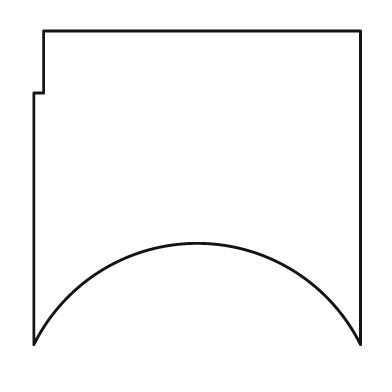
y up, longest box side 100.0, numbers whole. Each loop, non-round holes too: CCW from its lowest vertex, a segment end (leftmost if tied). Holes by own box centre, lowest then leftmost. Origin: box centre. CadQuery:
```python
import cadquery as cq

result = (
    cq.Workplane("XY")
    .moveTo(-50.0, -48.0)
    .threePointArc((0.0, -17.0), (50.0, -48.0))
    .lineTo(50.0, 48.0)
    .lineTo(-47.0, 48.0)
    .lineTo(-47.0, 29.0)
    .lineTo(-50.0, 29.0)
    .close()
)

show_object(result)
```